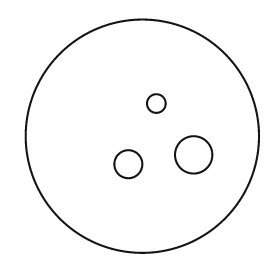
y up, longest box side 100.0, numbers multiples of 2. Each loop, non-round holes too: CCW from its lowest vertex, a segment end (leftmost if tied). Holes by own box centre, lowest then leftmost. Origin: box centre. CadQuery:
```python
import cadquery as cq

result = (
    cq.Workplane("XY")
    .moveTo(0.0, 0.0)
    .circle(50.0)
    .moveTo(-6.0, -12.0)
    .circle(6.0)
    .moveTo(22.0, -8.0)
    .circle(8.0)
    .moveTo(6.0, 14.0)
    .circle(4.0)
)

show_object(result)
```